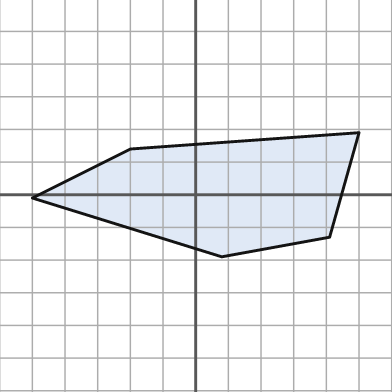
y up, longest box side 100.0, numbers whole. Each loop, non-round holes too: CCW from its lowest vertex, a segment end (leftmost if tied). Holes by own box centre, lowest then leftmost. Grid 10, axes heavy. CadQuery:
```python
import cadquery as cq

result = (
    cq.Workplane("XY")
    .moveTo(8.0, -19.0)
    .lineTo(41.0, -13.0)
    .lineTo(50.0, 19.0)
    .lineTo(-20.0, 14.0)
    .lineTo(-50.0, -1.0)
    .close()
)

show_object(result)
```